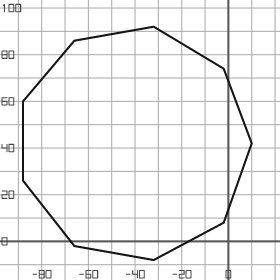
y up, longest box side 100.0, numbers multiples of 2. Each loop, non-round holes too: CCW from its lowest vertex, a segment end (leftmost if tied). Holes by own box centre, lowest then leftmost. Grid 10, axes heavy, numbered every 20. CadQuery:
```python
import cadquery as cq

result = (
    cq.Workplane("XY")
    .moveTo(-32.0, -8.0)
    .lineTo(-2.0, 8.0)
    .lineTo(10.0, 42.0)
    .lineTo(-2.0, 74.0)
    .lineTo(-32.0, 92.0)
    .lineTo(-66.0, 86.0)
    .lineTo(-88.0, 60.0)
    .lineTo(-88.0, 26.0)
    .lineTo(-66.0, -2.0)
    .close()
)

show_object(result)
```